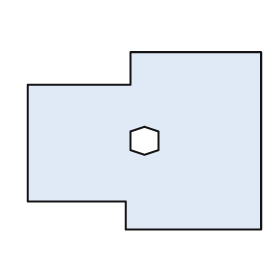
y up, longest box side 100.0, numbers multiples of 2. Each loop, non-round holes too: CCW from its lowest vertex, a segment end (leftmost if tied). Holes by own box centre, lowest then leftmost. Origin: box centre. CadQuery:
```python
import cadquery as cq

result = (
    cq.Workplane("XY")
    .moveTo(-8.0, -38.0)
    .lineTo(50.0, -38.0)
    .lineTo(50.0, 38.0)
    .lineTo(-6.0, 38.0)
    .lineTo(-6.0, 24.0)
    .lineTo(-50.0, 24.0)
    .lineTo(-50.0, -26.0)
    .lineTo(-8.0, -26.0)
    .close()
    .moveTo(0.0, -6.0)
    .lineTo(6.0, -4.0)
    .lineTo(6.0, 4.0)
    .lineTo(0.0, 6.0)
    .lineTo(-6.0, 4.0)
    .lineTo(-6.0, -4.0)
    .close()
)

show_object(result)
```